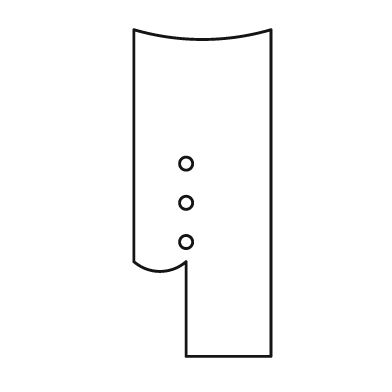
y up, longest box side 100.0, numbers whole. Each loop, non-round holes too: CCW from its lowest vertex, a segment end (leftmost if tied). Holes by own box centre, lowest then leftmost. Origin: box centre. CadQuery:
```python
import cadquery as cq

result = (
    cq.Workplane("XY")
    .moveTo(-5.0, -50.0)
    .lineTo(21.0, -50.0)
    .lineTo(21.0, 50.0)
    .threePointArc((0.0, 47.0), (-21.0, 50.0))
    .lineTo(-21.0, -21.0)
    .threePointArc((-13.0, -24.0), (-5.0, -21.0))
    .close()
    .moveTo(-5.0, -15.0)
    .circle(2.0)
    .moveTo(-5.0, -3.0)
    .circle(2.0)
    .moveTo(-5.0, 9.0)
    .circle(2.0)
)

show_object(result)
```